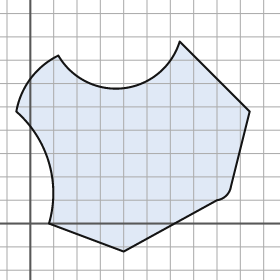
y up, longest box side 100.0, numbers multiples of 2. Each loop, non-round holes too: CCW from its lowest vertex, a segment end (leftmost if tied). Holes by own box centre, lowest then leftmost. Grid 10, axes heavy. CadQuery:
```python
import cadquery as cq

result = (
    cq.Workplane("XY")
    .moveTo(40.0, -12.0)
    .lineTo(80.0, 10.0)
    .threePointArc((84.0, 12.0), (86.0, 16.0))
    .lineTo(94.0, 48.0)
    .lineTo(64.0, 78.0)
    .threePointArc((40.0, 58.0), (12.0, 72.0))
    .threePointArc((0.0, 62.0), (-6.0, 48.0))
    .threePointArc((8.0, 26.0), (8.0, 0.0))
    .close()
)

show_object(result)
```